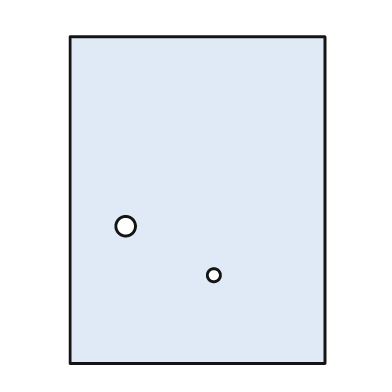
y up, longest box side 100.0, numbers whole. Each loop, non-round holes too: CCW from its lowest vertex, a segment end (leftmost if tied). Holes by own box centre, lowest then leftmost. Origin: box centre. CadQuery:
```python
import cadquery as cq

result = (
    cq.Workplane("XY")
    .moveTo(-39.0, -50.0)
    .lineTo(39.0, -50.0)
    .lineTo(39.0, 50.0)
    .lineTo(-39.0, 50.0)
    .close()
    .moveTo(5.0, -23.0)
    .circle(2.0)
    .moveTo(-22.0, -8.0)
    .circle(3.0)
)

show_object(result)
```